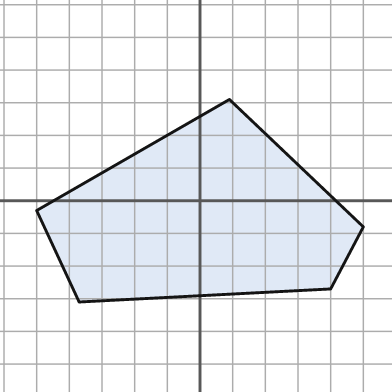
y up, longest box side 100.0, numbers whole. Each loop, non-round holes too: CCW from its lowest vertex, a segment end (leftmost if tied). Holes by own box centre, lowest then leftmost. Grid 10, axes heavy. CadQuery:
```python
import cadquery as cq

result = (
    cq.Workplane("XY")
    .moveTo(-37.0, -31.0)
    .lineTo(40.0, -27.0)
    .lineTo(50.0, -8.0)
    .lineTo(9.0, 31.0)
    .lineTo(-50.0, -3.0)
    .close()
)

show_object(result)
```